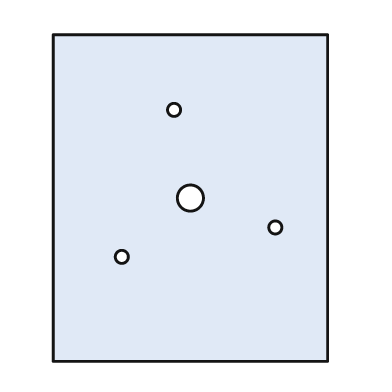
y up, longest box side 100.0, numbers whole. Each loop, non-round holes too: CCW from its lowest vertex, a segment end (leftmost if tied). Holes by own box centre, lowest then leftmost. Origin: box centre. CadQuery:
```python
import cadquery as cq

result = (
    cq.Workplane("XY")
    .moveTo(-42.0, -50.0)
    .lineTo(42.0, -50.0)
    .lineTo(42.0, 50.0)
    .lineTo(-42.0, 50.0)
    .close()
    .moveTo(-21.0, -18.0)
    .circle(2.0)
    .moveTo(26.0, -9.0)
    .circle(2.0)
    .moveTo(0.0, 0.0)
    .circle(4.0)
    .moveTo(-5.0, 27.0)
    .circle(2.0)
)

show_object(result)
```